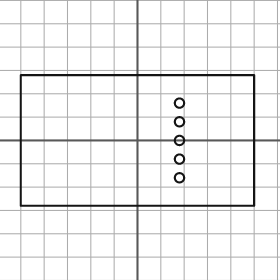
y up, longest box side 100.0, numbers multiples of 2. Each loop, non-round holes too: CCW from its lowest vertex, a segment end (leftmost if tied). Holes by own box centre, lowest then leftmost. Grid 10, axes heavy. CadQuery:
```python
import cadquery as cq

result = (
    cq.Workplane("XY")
    .moveTo(-50.0, -28.0)
    .lineTo(50.0, -28.0)
    .lineTo(50.0, 28.0)
    .lineTo(-50.0, 28.0)
    .close()
    .moveTo(18.0, -16.0)
    .circle(2.0)
    .moveTo(18.0, -8.0)
    .circle(2.0)
    .moveTo(18.0, 0.0)
    .circle(2.0)
    .moveTo(18.0, 8.0)
    .circle(2.0)
    .moveTo(18.0, 16.0)
    .circle(2.0)
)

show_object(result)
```